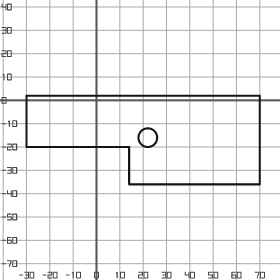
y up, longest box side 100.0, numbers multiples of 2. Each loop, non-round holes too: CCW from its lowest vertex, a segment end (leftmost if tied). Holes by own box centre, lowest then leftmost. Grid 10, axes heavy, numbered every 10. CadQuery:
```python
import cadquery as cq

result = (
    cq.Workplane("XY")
    .moveTo(14.0, -36.0)
    .lineTo(70.0, -36.0)
    .lineTo(70.0, 2.0)
    .lineTo(-30.0, 2.0)
    .lineTo(-30.0, -20.0)
    .lineTo(14.0, -20.0)
    .close()
    .moveTo(22.0, -16.0)
    .circle(4.0)
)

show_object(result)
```